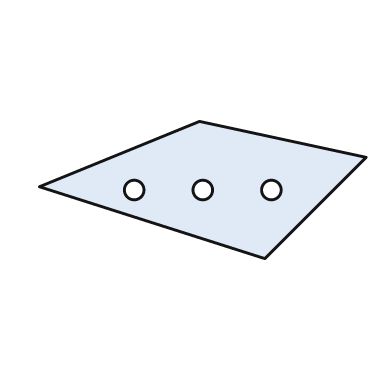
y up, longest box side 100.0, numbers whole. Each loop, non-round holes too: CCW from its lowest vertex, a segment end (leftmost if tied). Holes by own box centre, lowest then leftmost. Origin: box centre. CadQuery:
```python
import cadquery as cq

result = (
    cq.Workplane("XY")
    .moveTo(19.0, -21.0)
    .lineTo(50.0, 10.0)
    .lineTo(-1.0, 21.0)
    .lineTo(-50.0, 1.0)
    .close()
    .moveTo(-21.0, 0.0)
    .circle(3.0)
    .moveTo(0.0, 0.0)
    .circle(3.0)
    .moveTo(21.0, 0.0)
    .circle(3.0)
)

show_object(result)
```